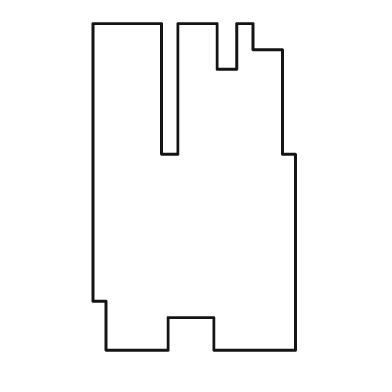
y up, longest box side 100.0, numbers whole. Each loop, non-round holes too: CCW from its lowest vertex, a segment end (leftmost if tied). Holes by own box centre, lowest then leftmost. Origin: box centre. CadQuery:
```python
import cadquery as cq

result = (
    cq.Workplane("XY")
    .moveTo(-27.0, -50.0)
    .lineTo(-8.0, -50.0)
    .lineTo(-8.0, -40.0)
    .lineTo(6.0, -40.0)
    .lineTo(6.0, -50.0)
    .lineTo(31.0, -50.0)
    .lineTo(31.0, 10.0)
    .lineTo(27.0, 10.0)
    .lineTo(27.0, 42.0)
    .lineTo(18.0, 42.0)
    .lineTo(18.0, 50.0)
    .lineTo(13.0, 50.0)
    .lineTo(13.0, 36.0)
    .lineTo(7.0, 36.0)
    .lineTo(7.0, 50.0)
    .lineTo(-5.0, 50.0)
    .lineTo(-5.0, 10.0)
    .lineTo(-10.0, 10.0)
    .lineTo(-10.0, 50.0)
    .lineTo(-31.0, 50.0)
    .lineTo(-31.0, -35.0)
    .lineTo(-27.0, -35.0)
    .close()
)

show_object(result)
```